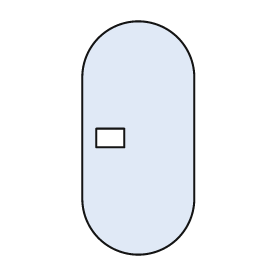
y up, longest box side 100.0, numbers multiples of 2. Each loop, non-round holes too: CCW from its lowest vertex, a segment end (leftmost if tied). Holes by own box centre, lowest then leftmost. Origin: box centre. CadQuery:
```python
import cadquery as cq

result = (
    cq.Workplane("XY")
    .moveTo(-24.0, -26.0)
    .threePointArc((0.0, -50.0), (24.0, -26.0))
    .lineTo(24.0, 26.0)
    .threePointArc((0.0, 50.0), (-24.0, 26.0))
    .close()
    .moveTo(-18.0, -4.0)
    .lineTo(-6.0, -4.0)
    .lineTo(-6.0, 4.0)
    .lineTo(-18.0, 4.0)
    .close()
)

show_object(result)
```